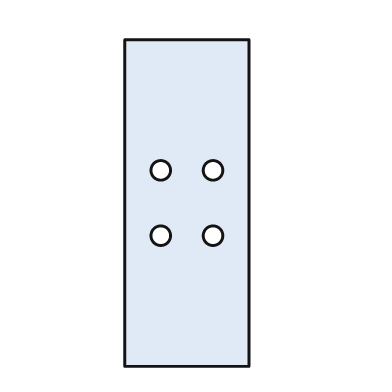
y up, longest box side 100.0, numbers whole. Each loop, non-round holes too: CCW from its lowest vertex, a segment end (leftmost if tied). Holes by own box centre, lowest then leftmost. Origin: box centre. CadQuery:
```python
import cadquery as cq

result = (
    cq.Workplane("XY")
    .moveTo(-19.0, -50.0)
    .lineTo(19.0, -50.0)
    .lineTo(19.0, 50.0)
    .lineTo(-19.0, 50.0)
    .close()
    .moveTo(-8.0, -10.0)
    .circle(3.0)
    .moveTo(8.0, -10.0)
    .circle(3.0)
    .moveTo(-8.0, 10.0)
    .circle(3.0)
    .moveTo(8.0, 10.0)
    .circle(3.0)
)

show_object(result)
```